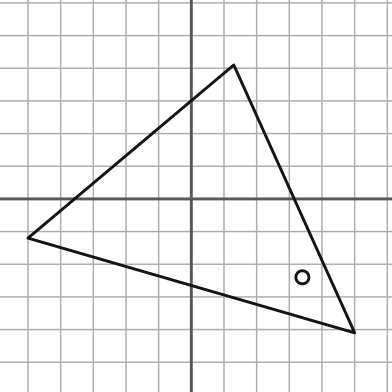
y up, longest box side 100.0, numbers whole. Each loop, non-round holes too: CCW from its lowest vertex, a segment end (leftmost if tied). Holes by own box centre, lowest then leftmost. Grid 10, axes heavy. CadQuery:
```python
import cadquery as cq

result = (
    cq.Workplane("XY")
    .moveTo(50.0, -41.0)
    .lineTo(13.0, 41.0)
    .lineTo(-50.0, -12.0)
    .close()
    .moveTo(34.0, -24.0)
    .circle(2.0)
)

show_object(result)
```